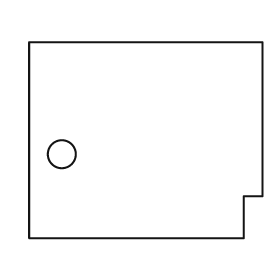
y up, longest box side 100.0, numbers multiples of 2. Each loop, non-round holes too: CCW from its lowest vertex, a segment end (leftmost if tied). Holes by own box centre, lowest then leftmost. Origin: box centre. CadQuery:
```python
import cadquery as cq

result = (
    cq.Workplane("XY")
    .moveTo(-50.0, -42.0)
    .lineTo(42.0, -42.0)
    .lineTo(42.0, -24.0)
    .lineTo(50.0, -24.0)
    .lineTo(50.0, 42.0)
    .lineTo(-50.0, 42.0)
    .close()
    .moveTo(-36.0, -6.0)
    .circle(6.0)
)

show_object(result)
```